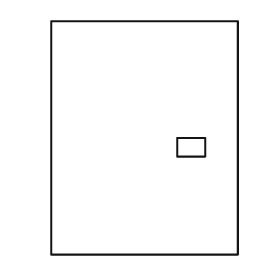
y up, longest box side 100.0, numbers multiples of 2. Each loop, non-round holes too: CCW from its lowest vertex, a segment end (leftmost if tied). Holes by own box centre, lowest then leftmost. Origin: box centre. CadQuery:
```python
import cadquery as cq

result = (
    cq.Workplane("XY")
    .moveTo(-40.0, -50.0)
    .lineTo(40.0, -50.0)
    .lineTo(40.0, 50.0)
    .lineTo(-40.0, 50.0)
    .close()
    .moveTo(14.0, -8.0)
    .lineTo(26.0, -8.0)
    .lineTo(26.0, 0.0)
    .lineTo(14.0, 0.0)
    .close()
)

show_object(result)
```